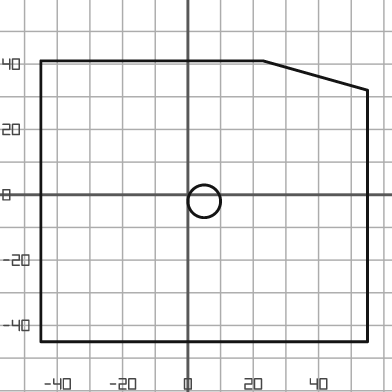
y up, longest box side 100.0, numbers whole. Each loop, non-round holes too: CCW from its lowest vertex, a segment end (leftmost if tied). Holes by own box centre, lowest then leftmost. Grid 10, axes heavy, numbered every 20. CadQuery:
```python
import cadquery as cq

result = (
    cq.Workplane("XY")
    .moveTo(-45.0, -45.0)
    .lineTo(55.0, -45.0)
    .lineTo(55.0, 32.0)
    .lineTo(23.0, 41.0)
    .lineTo(-45.0, 41.0)
    .close()
    .moveTo(5.0, -2.0)
    .circle(5.0)
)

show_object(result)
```